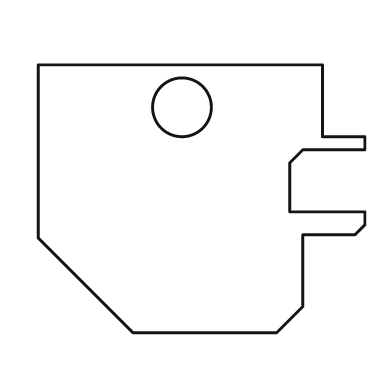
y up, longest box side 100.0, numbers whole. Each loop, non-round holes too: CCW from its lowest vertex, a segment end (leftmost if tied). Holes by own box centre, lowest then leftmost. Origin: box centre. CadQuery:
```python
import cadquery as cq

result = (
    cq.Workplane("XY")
    .moveTo(-21.0, -41.0)
    .lineTo(23.0, -41.0)
    .lineTo(31.0, -33.0)
    .lineTo(31.0, -11.0)
    .lineTo(47.0, -11.0)
    .lineTo(50.0, -8.0)
    .lineTo(50.0, -4.0)
    .lineTo(27.0, -4.0)
    .lineTo(27.0, 11.0)
    .lineTo(31.0, 15.0)
    .lineTo(50.0, 15.0)
    .lineTo(50.0, 19.0)
    .lineTo(37.0, 19.0)
    .lineTo(37.0, 41.0)
    .lineTo(-50.0, 41.0)
    .lineTo(-50.0, -12.0)
    .close()
    .moveTo(-6.0, 28.0)
    .circle(9.0)
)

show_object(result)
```